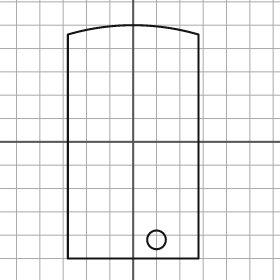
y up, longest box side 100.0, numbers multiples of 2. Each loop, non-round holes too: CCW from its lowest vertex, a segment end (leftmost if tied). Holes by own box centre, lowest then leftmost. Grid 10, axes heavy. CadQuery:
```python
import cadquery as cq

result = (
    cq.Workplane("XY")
    .moveTo(-28.0, -50.0)
    .lineTo(28.0, -50.0)
    .lineTo(28.0, 46.0)
    .threePointArc((0.0, 50.0), (-28.0, 46.0))
    .close()
    .moveTo(10.0, -42.0)
    .circle(4.0)
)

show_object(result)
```